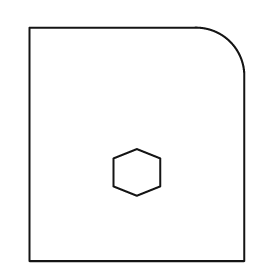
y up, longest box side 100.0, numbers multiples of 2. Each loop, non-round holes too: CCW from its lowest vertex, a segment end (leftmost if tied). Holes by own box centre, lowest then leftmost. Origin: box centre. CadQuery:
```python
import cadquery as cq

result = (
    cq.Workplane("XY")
    .moveTo(-46.0, -50.0)
    .lineTo(46.0, -50.0)
    .lineTo(46.0, 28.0)
    .threePointArc((40.0, 44.0), (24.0, 50.0))
    .lineTo(-46.0, 50.0)
    .close()
    .moveTo(0.0, -22.0)
    .lineTo(10.0, -18.0)
    .lineTo(10.0, -6.0)
    .lineTo(0.0, -2.0)
    .lineTo(-10.0, -6.0)
    .lineTo(-10.0, -18.0)
    .close()
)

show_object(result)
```